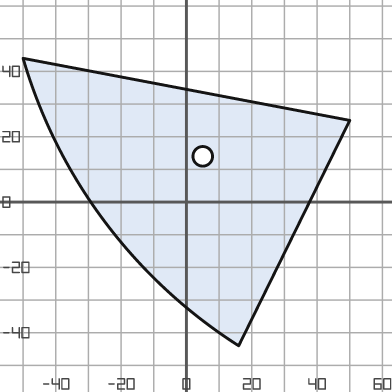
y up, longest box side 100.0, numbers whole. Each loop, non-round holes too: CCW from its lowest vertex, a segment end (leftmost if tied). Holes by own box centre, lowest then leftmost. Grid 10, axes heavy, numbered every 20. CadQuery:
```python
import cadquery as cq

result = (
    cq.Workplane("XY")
    .moveTo(16.0, -44.0)
    .lineTo(50.0, 25.0)
    .lineTo(-50.0, 44.0)
    .threePointArc((-25.0, -6.0), (16.0, -44.0))
    .close()
    .moveTo(5.0, 14.0)
    .circle(3.0)
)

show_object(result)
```